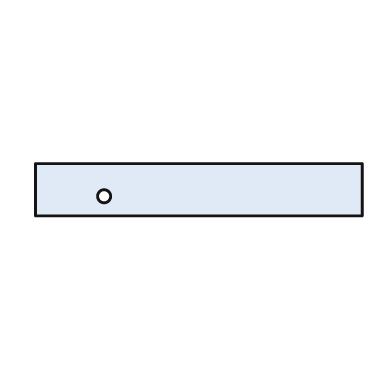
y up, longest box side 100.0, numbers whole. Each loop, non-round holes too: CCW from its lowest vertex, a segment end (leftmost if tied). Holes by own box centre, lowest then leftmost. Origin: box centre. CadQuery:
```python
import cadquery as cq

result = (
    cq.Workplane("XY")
    .moveTo(-50.0, -8.0)
    .lineTo(50.0, -8.0)
    .lineTo(50.0, 8.0)
    .lineTo(-50.0, 8.0)
    .close()
    .moveTo(-29.0, -2.0)
    .circle(2.0)
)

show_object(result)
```